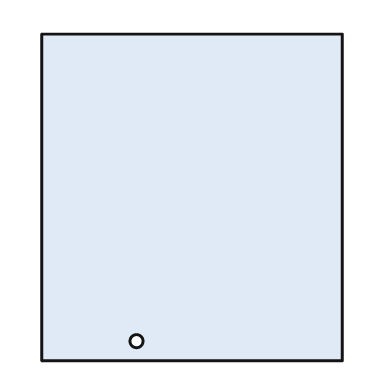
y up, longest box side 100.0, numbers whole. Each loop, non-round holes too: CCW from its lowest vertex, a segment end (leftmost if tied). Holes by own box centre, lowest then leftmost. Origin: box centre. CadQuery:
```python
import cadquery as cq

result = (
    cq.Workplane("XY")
    .moveTo(-46.0, -50.0)
    .lineTo(46.0, -50.0)
    .lineTo(46.0, 50.0)
    .lineTo(-46.0, 50.0)
    .close()
    .moveTo(-17.0, -44.0)
    .circle(2.0)
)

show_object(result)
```